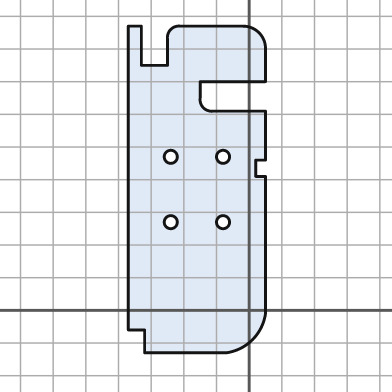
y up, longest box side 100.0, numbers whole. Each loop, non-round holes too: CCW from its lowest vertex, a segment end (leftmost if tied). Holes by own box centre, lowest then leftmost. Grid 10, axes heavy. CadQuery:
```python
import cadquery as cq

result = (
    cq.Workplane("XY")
    .moveTo(-32.0, -13.0)
    .lineTo(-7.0, -13.0)
    .threePointArc((1.0, -9.0), (5.0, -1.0))
    .lineTo(5.0, 41.0)
    .lineTo(2.0, 41.0)
    .lineTo(2.0, 46.0)
    .lineTo(5.0, 46.0)
    .lineTo(5.0, 61.0)
    .lineTo(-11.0, 61.0)
    .threePointArc((-14.0, 62.0), (-15.0, 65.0))
    .lineTo(-15.0, 70.0)
    .lineTo(5.0, 70.0)
    .lineTo(5.0, 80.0)
    .threePointArc((3.0, 85.0), (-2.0, 87.0))
    .lineTo(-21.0, 87.0)
    .threePointArc((-24.0, 86.0), (-25.0, 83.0))
    .lineTo(-25.0, 75.0)
    .lineTo(-33.0, 75.0)
    .lineTo(-33.0, 87.0)
    .lineTo(-37.0, 87.0)
    .lineTo(-37.0, -6.0)
    .lineTo(-32.0, -6.0)
    .close()
    .moveTo(-24.0, 27.0)
    .circle(2.0)
    .moveTo(-8.0, 27.0)
    .circle(2.0)
    .moveTo(-24.0, 47.0)
    .circle(2.0)
    .moveTo(-8.0, 47.0)
    .circle(2.0)
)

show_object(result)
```